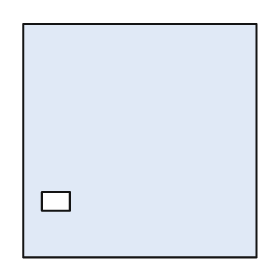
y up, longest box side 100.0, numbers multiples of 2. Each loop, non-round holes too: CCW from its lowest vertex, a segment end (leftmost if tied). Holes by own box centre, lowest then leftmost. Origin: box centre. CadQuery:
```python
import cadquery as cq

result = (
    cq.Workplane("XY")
    .moveTo(-50.0, -50.0)
    .lineTo(50.0, -50.0)
    .lineTo(50.0, 50.0)
    .lineTo(-50.0, 50.0)
    .close()
    .moveTo(-42.0, -30.0)
    .lineTo(-30.0, -30.0)
    .lineTo(-30.0, -22.0)
    .lineTo(-42.0, -22.0)
    .close()
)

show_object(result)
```